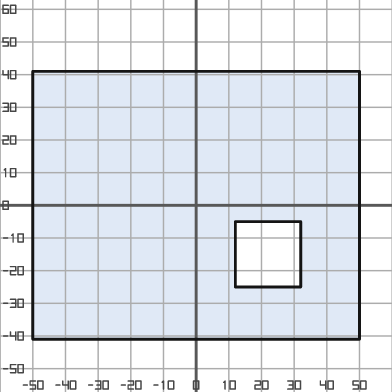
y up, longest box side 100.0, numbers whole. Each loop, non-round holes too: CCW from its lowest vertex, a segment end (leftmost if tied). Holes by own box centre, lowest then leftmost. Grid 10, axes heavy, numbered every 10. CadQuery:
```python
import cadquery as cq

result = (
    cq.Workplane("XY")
    .moveTo(-50.0, -41.0)
    .lineTo(50.0, -41.0)
    .lineTo(50.0, 41.0)
    .lineTo(-50.0, 41.0)
    .close()
    .moveTo(12.0, -25.0)
    .lineTo(32.0, -25.0)
    .lineTo(32.0, -5.0)
    .lineTo(12.0, -5.0)
    .close()
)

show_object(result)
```